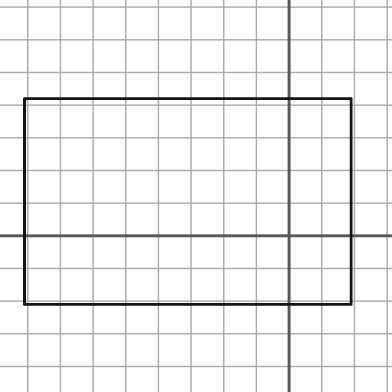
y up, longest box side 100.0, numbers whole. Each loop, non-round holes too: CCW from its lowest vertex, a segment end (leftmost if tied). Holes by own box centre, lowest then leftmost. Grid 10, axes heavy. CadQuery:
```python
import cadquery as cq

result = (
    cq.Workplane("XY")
    .moveTo(-81.0, -21.0)
    .lineTo(19.0, -21.0)
    .lineTo(19.0, 42.0)
    .lineTo(-81.0, 42.0)
    .close()
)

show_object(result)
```